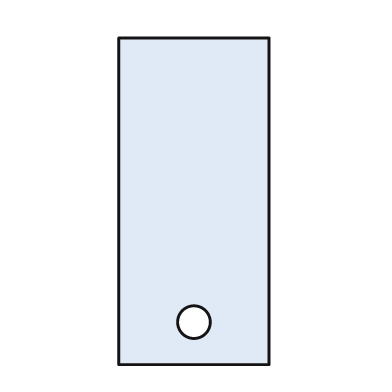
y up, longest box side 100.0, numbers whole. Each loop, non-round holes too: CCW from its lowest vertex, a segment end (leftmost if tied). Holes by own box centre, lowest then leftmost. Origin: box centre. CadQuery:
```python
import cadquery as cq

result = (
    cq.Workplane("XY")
    .moveTo(-23.0, -50.0)
    .lineTo(23.0, -50.0)
    .lineTo(23.0, 50.0)
    .lineTo(-23.0, 50.0)
    .close()
    .moveTo(0.0, -37.0)
    .circle(5.0)
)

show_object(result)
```